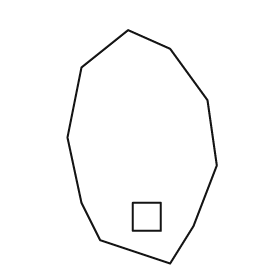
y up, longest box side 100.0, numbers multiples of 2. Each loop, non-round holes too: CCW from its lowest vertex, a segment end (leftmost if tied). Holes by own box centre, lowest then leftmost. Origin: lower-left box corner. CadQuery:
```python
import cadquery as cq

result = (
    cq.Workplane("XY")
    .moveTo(44.0, 0.0)
    .lineTo(54.0, 16.0)
    .lineTo(64.0, 42.0)
    .lineTo(60.0, 70.0)
    .lineTo(44.0, 92.0)
    .lineTo(26.0, 100.0)
    .lineTo(6.0, 84.0)
    .lineTo(0.0, 54.0)
    .lineTo(6.0, 26.0)
    .lineTo(14.0, 10.0)
    .close()
    .moveTo(28.0, 14.0)
    .lineTo(40.0, 14.0)
    .lineTo(40.0, 26.0)
    .lineTo(28.0, 26.0)
    .close()
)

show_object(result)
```